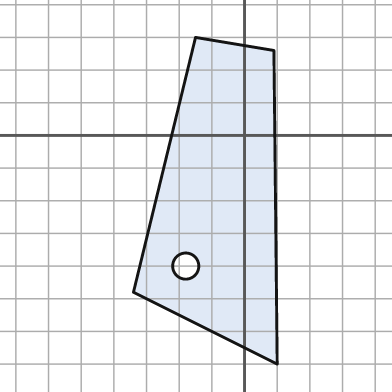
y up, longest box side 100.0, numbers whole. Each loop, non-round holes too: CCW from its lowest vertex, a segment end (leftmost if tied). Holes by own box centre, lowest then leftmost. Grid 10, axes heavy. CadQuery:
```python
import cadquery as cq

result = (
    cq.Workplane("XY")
    .moveTo(10.0, -70.0)
    .lineTo(9.0, 26.0)
    .lineTo(-15.0, 30.0)
    .lineTo(-34.0, -48.0)
    .close()
    .moveTo(-18.0, -40.0)
    .circle(4.0)
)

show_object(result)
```